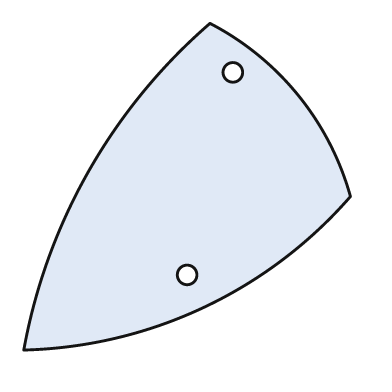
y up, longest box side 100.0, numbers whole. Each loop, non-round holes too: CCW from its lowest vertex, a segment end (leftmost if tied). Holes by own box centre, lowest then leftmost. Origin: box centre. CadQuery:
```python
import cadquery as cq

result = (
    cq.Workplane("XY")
    .moveTo(-50.0, -50.0)
    .threePointArc((5.0, -37.0), (50.0, -3.0))
    .threePointArc((34.0, 28.0), (7.0, 50.0))
    .threePointArc((-30.0, 5.0), (-50.0, -50.0))
    .close()
    .moveTo(0.0, -27.0)
    .circle(3.0)
    .moveTo(14.0, 35.0)
    .circle(3.0)
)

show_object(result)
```